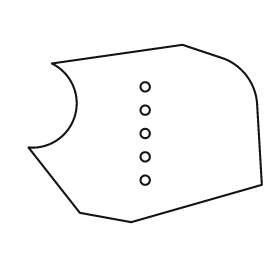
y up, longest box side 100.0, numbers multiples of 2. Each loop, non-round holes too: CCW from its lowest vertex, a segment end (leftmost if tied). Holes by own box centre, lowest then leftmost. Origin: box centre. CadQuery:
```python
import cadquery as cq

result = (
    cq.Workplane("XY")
    .moveTo(-6.0, -38.0)
    .lineTo(50.0, -22.0)
    .lineTo(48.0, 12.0)
    .threePointArc((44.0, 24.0), (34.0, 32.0))
    .lineTo(16.0, 38.0)
    .lineTo(-40.0, 30.0)
    .threePointArc((-30.0, 8.0), (-50.0, -6.0))
    .lineTo(-28.0, -34.0)
    .close()
    .moveTo(0.0, -20.0)
    .circle(2.0)
    .moveTo(0.0, -10.0)
    .circle(2.0)
    .moveTo(0.0, 0.0)
    .circle(2.0)
    .moveTo(0.0, 10.0)
    .circle(2.0)
    .moveTo(0.0, 20.0)
    .circle(2.0)
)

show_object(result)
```